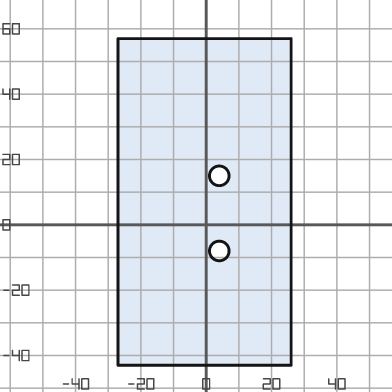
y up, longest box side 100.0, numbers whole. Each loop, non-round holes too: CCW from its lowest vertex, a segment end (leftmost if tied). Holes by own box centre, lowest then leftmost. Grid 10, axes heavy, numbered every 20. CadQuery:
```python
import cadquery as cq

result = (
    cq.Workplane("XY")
    .moveTo(-27.0, -43.0)
    .lineTo(26.0, -43.0)
    .lineTo(26.0, 57.0)
    .lineTo(-27.0, 57.0)
    .close()
    .moveTo(4.0, -8.0)
    .circle(3.0)
    .moveTo(4.0, 15.0)
    .circle(3.0)
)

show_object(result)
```